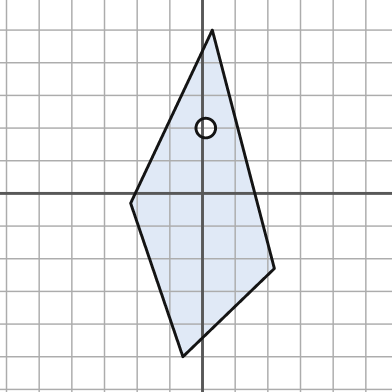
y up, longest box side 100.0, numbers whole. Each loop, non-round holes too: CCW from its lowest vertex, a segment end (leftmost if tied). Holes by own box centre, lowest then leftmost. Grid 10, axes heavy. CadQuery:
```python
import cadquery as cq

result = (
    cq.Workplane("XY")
    .moveTo(-6.0, -50.0)
    .lineTo(22.0, -23.0)
    .lineTo(3.0, 50.0)
    .lineTo(-22.0, -3.0)
    .close()
    .moveTo(1.0, 20.0)
    .circle(3.0)
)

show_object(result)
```